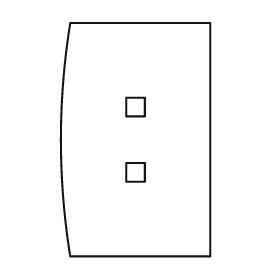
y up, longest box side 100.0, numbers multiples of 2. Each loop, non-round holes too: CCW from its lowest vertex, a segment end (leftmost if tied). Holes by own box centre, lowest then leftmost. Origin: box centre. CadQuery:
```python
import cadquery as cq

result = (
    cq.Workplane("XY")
    .moveTo(-28.0, -50.0)
    .lineTo(32.0, -50.0)
    .lineTo(32.0, 50.0)
    .lineTo(-28.0, 50.0)
    .threePointArc((-32.0, 0.0), (-28.0, -50.0))
    .close()
    .moveTo(-4.0, -18.0)
    .lineTo(4.0, -18.0)
    .lineTo(4.0, -10.0)
    .lineTo(-4.0, -10.0)
    .close()
    .moveTo(-4.0, 10.0)
    .lineTo(4.0, 10.0)
    .lineTo(4.0, 18.0)
    .lineTo(-4.0, 18.0)
    .close()
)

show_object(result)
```